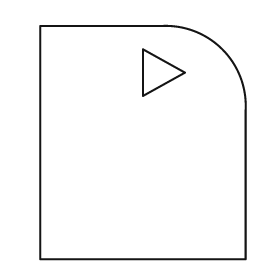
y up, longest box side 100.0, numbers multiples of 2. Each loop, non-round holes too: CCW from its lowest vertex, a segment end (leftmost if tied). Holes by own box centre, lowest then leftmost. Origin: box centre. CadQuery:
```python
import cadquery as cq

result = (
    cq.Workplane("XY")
    .moveTo(-44.0, -50.0)
    .lineTo(44.0, -50.0)
    .lineTo(44.0, 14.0)
    .threePointArc((34.0, 40.0), (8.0, 50.0))
    .lineTo(-44.0, 50.0)
    .close()
    .moveTo(0.0, 20.0)
    .lineTo(18.0, 30.0)
    .lineTo(0.0, 40.0)
    .close()
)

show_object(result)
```